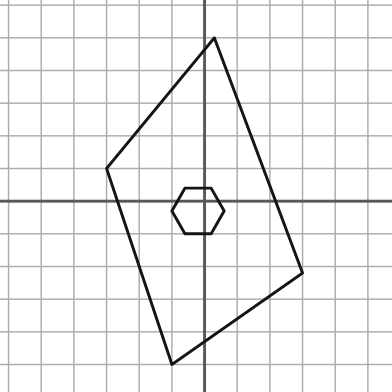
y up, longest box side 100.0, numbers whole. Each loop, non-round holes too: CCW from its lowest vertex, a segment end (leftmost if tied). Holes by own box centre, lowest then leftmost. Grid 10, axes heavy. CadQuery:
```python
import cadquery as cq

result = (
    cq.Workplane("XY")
    .moveTo(-10.0, -50.0)
    .lineTo(30.0, -22.0)
    .lineTo(3.0, 50.0)
    .lineTo(-30.0, 10.0)
    .close()
    .moveTo(-6.0, -10.0)
    .lineTo(2.0, -10.0)
    .lineTo(6.0, -3.0)
    .lineTo(2.0, 4.0)
    .lineTo(-6.0, 4.0)
    .lineTo(-10.0, -3.0)
    .close()
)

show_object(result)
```